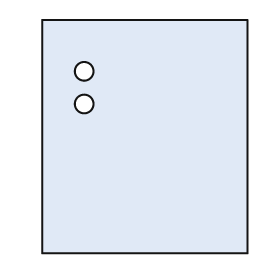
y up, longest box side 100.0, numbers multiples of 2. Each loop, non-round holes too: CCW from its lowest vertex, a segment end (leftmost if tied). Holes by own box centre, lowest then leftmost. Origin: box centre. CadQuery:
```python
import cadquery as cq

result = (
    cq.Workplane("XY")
    .moveTo(-44.0, -50.0)
    .lineTo(44.0, -50.0)
    .lineTo(44.0, 50.0)
    .lineTo(-44.0, 50.0)
    .close()
    .moveTo(-26.0, 14.0)
    .circle(4.0)
    .moveTo(-26.0, 28.0)
    .circle(4.0)
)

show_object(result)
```